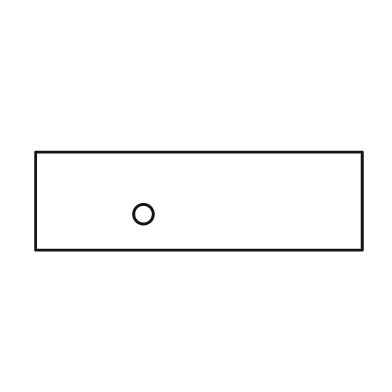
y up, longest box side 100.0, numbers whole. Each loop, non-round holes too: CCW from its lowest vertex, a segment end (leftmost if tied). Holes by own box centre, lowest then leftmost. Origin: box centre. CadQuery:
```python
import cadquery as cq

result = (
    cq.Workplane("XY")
    .moveTo(-50.0, -15.0)
    .lineTo(50.0, -15.0)
    .lineTo(50.0, 15.0)
    .lineTo(-50.0, 15.0)
    .close()
    .moveTo(-17.0, -4.0)
    .circle(3.0)
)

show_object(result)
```